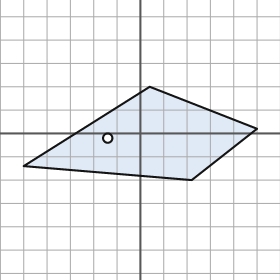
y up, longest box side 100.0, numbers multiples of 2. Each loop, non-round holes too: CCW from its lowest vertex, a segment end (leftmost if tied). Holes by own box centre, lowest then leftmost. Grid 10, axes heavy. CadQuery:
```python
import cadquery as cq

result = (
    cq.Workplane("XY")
    .moveTo(22.0, -20.0)
    .lineTo(50.0, 2.0)
    .lineTo(4.0, 20.0)
    .lineTo(-50.0, -14.0)
    .close()
    .moveTo(-14.0, -2.0)
    .circle(2.0)
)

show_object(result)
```